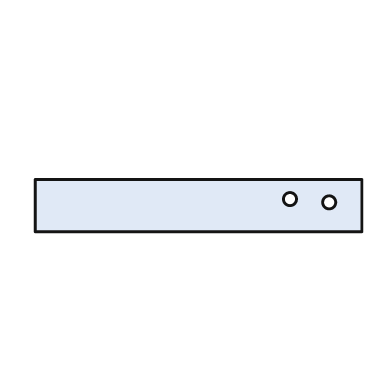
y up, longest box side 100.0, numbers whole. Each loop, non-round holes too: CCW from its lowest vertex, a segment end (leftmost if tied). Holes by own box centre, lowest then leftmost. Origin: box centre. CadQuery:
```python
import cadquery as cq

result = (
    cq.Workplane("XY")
    .moveTo(-50.0, -8.0)
    .lineTo(50.0, -8.0)
    .lineTo(50.0, 8.0)
    .lineTo(-50.0, 8.0)
    .close()
    .moveTo(40.0, 1.0)
    .circle(2.0)
    .moveTo(28.0, 2.0)
    .circle(2.0)
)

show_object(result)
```